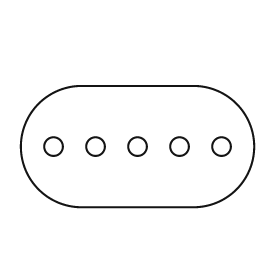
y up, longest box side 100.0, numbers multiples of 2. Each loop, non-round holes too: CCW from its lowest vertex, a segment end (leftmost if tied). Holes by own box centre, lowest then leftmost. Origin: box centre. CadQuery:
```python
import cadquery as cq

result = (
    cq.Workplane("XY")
    .moveTo(-24.0, -26.0)
    .lineTo(24.0, -26.0)
    .threePointArc((50.0, 0.0), (24.0, 26.0))
    .lineTo(-24.0, 26.0)
    .threePointArc((-50.0, 0.0), (-24.0, -26.0))
    .close()
    .moveTo(-36.0, 0.0)
    .circle(4.0)
    .moveTo(-18.0, 0.0)
    .circle(4.0)
    .moveTo(0.0, 0.0)
    .circle(4.0)
    .moveTo(18.0, 0.0)
    .circle(4.0)
    .moveTo(36.0, 0.0)
    .circle(4.0)
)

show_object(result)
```